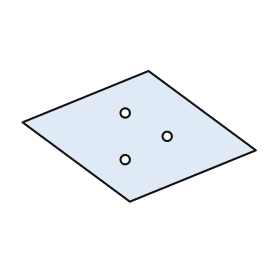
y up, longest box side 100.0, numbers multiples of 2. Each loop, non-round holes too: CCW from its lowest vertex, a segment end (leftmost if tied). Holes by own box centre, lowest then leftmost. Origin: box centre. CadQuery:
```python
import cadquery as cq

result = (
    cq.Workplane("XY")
    .moveTo(-4.0, -28.0)
    .lineTo(50.0, -6.0)
    .lineTo(4.0, 28.0)
    .lineTo(-50.0, 6.0)
    .close()
    .moveTo(-6.0, -10.0)
    .circle(2.0)
    .moveTo(12.0, 0.0)
    .circle(2.0)
    .moveTo(-6.0, 10.0)
    .circle(2.0)
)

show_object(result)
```